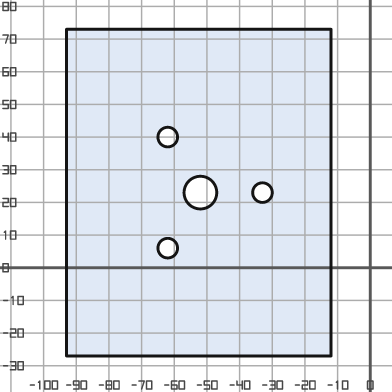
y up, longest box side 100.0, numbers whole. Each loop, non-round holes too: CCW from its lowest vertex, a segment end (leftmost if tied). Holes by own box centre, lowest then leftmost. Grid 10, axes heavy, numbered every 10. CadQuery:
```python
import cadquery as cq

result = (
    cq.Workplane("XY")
    .moveTo(-93.0, -27.0)
    .lineTo(-12.0, -27.0)
    .lineTo(-12.0, 73.0)
    .lineTo(-93.0, 73.0)
    .close()
    .moveTo(-62.0, 6.0)
    .circle(3.0)
    .moveTo(-52.0, 23.0)
    .circle(5.0)
    .moveTo(-33.0, 23.0)
    .circle(3.0)
    .moveTo(-62.0, 40.0)
    .circle(3.0)
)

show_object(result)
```